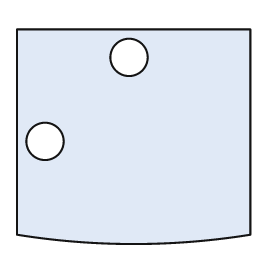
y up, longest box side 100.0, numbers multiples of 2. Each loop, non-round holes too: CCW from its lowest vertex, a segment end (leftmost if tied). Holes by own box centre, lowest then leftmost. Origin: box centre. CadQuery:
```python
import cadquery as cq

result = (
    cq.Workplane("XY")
    .moveTo(-50.0, -42.0)
    .threePointArc((0.0, -46.0), (50.0, -42.0))
    .lineTo(50.0, 46.0)
    .lineTo(-50.0, 46.0)
    .close()
    .moveTo(-38.0, -2.0)
    .circle(8.0)
    .moveTo(-2.0, 34.0)
    .circle(8.0)
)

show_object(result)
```